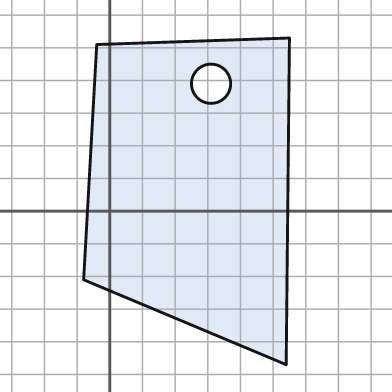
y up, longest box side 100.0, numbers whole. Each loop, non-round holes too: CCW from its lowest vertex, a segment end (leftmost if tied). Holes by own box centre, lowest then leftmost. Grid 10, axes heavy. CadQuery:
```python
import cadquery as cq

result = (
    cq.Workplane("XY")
    .moveTo(54.0, -47.0)
    .lineTo(55.0, 53.0)
    .lineTo(-4.0, 51.0)
    .lineTo(-8.0, -21.0)
    .close()
    .moveTo(31.0, 39.0)
    .circle(6.0)
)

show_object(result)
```